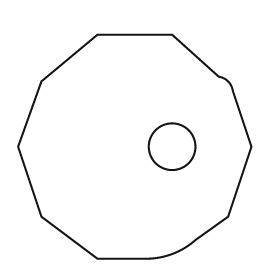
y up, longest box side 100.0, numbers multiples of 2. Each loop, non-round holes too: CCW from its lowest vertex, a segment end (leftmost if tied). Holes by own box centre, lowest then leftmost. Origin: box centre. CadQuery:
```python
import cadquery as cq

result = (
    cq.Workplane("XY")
    .moveTo(-16.0, -48.0)
    .lineTo(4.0, -48.0)
    .threePointArc((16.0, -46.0), (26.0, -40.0))
    .lineTo(40.0, -30.0)
    .lineTo(50.0, 0.0)
    .lineTo(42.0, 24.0)
    .threePointArc((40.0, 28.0), (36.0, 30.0))
    .lineTo(16.0, 48.0)
    .lineTo(-16.0, 48.0)
    .lineTo(-40.0, 28.0)
    .lineTo(-50.0, 0.0)
    .lineTo(-40.0, -30.0)
    .close()
    .moveTo(16.0, 0.0)
    .circle(10.0)
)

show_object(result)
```